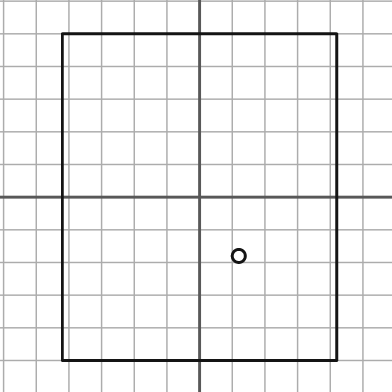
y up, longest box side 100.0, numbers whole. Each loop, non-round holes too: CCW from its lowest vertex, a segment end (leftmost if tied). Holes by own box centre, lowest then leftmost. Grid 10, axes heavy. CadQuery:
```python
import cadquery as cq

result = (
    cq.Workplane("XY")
    .moveTo(-42.0, -50.0)
    .lineTo(42.0, -50.0)
    .lineTo(42.0, 50.0)
    .lineTo(-42.0, 50.0)
    .close()
    .moveTo(12.0, -18.0)
    .circle(2.0)
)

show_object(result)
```